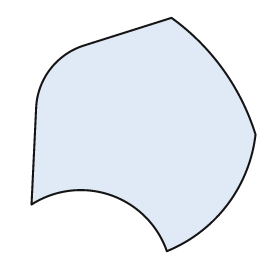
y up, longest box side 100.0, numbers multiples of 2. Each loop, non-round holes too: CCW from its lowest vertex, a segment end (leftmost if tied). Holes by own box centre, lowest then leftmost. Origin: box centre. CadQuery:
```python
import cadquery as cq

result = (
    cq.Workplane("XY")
    .moveTo(10.0, -50.0)
    .threePointArc((36.0, -30.0), (48.0, 0.0))
    .threePointArc((34.0, 28.0), (12.0, 50.0))
    .lineTo(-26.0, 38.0)
    .threePointArc((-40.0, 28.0), (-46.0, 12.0))
    .lineTo(-48.0, -30.0)
    .threePointArc((-14.0, -26.0), (10.0, -50.0))
    .close()
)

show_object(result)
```